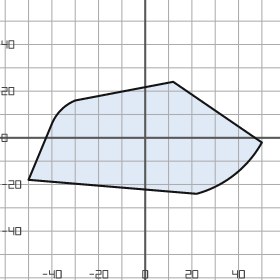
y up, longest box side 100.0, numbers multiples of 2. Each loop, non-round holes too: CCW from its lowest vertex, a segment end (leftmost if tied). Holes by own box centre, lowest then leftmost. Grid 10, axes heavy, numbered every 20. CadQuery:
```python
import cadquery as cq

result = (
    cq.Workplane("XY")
    .moveTo(22.0, -24.0)
    .threePointArc((38.0, -16.0), (50.0, -2.0))
    .lineTo(12.0, 24.0)
    .lineTo(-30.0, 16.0)
    .threePointArc((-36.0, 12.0), (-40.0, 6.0))
    .lineTo(-50.0, -18.0)
    .close()
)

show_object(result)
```